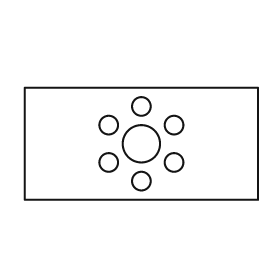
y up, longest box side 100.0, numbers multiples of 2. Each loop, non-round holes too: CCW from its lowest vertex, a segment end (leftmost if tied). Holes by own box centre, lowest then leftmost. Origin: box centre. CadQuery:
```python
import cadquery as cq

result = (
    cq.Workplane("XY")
    .moveTo(-50.0, -24.0)
    .lineTo(50.0, -24.0)
    .lineTo(50.0, 24.0)
    .lineTo(-50.0, 24.0)
    .close()
    .moveTo(0.0, -16.0)
    .circle(4.0)
    .moveTo(-14.0, -8.0)
    .circle(4.0)
    .moveTo(14.0, -8.0)
    .circle(4.0)
    .moveTo(0.0, 0.0)
    .circle(8.0)
    .moveTo(-14.0, 8.0)
    .circle(4.0)
    .moveTo(14.0, 8.0)
    .circle(4.0)
    .moveTo(0.0, 16.0)
    .circle(4.0)
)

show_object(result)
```